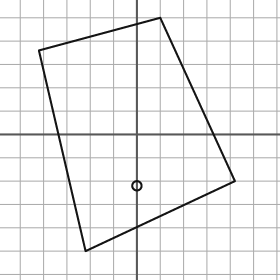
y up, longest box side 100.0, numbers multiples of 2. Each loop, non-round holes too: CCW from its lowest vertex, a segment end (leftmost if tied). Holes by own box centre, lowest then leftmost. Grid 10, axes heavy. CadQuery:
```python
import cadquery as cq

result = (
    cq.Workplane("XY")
    .moveTo(-22.0, -50.0)
    .lineTo(42.0, -20.0)
    .lineTo(10.0, 50.0)
    .lineTo(-42.0, 36.0)
    .close()
    .moveTo(0.0, -22.0)
    .circle(2.0)
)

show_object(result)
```